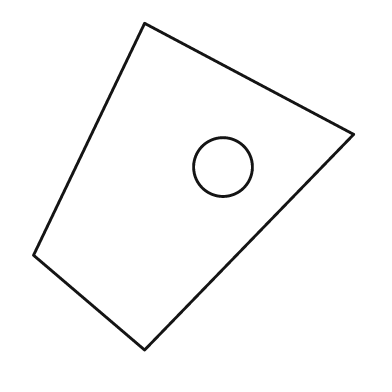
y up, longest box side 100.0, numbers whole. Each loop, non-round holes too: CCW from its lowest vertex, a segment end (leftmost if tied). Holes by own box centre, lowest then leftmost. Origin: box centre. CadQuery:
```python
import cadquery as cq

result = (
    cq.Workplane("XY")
    .moveTo(-15.0, -50.0)
    .lineTo(49.0, 16.0)
    .lineTo(-15.0, 50.0)
    .lineTo(-49.0, -21.0)
    .close()
    .moveTo(9.0, 6.0)
    .circle(9.0)
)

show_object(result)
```